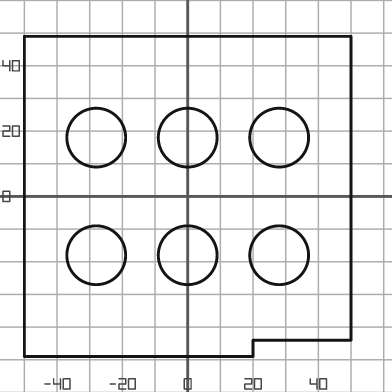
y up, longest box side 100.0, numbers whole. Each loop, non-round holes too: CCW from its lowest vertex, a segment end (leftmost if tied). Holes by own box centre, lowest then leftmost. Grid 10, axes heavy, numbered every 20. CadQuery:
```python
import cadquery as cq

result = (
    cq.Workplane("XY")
    .moveTo(-50.0, -49.0)
    .lineTo(20.0, -49.0)
    .lineTo(20.0, -44.0)
    .lineTo(50.0, -44.0)
    .lineTo(50.0, 49.0)
    .lineTo(-50.0, 49.0)
    .close()
    .moveTo(-28.0, -18.0)
    .circle(9.0)
    .moveTo(0.0, -18.0)
    .circle(9.0)
    .moveTo(28.0, -18.0)
    .circle(9.0)
    .moveTo(-28.0, 18.0)
    .circle(9.0)
    .moveTo(0.0, 18.0)
    .circle(9.0)
    .moveTo(28.0, 18.0)
    .circle(9.0)
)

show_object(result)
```